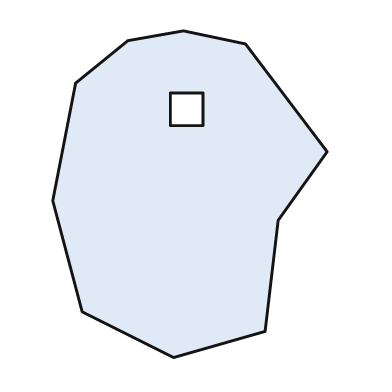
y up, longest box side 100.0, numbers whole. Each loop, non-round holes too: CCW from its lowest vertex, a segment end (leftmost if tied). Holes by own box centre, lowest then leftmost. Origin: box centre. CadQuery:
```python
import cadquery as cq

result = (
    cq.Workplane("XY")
    .moveTo(-5.0, -50.0)
    .lineTo(23.0, -42.0)
    .lineTo(27.0, -8.0)
    .lineTo(42.0, 13.0)
    .lineTo(17.0, 46.0)
    .lineTo(-2.0, 50.0)
    .lineTo(-19.0, 47.0)
    .lineTo(-35.0, 34.0)
    .lineTo(-42.0, -2.0)
    .lineTo(-33.0, -36.0)
    .close()
    .moveTo(-6.0, 21.0)
    .lineTo(4.0, 21.0)
    .lineTo(4.0, 31.0)
    .lineTo(-6.0, 31.0)
    .close()
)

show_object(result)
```